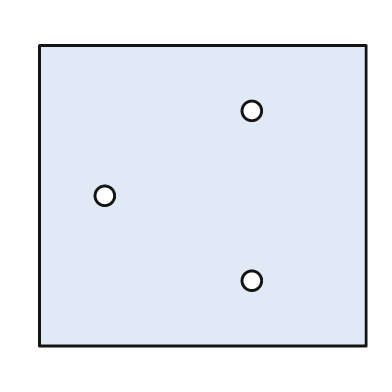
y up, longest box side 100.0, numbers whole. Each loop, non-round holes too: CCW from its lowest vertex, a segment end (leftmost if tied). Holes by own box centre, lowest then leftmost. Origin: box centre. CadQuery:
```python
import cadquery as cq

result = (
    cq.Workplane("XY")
    .moveTo(-50.0, -46.0)
    .lineTo(50.0, -46.0)
    .lineTo(50.0, 46.0)
    .lineTo(-50.0, 46.0)
    .close()
    .moveTo(15.0, -26.0)
    .circle(3.0)
    .moveTo(-30.0, 0.0)
    .circle(3.0)
    .moveTo(15.0, 26.0)
    .circle(3.0)
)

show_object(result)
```